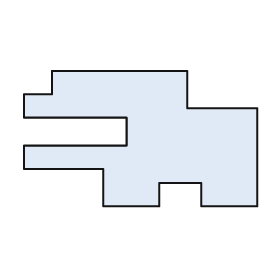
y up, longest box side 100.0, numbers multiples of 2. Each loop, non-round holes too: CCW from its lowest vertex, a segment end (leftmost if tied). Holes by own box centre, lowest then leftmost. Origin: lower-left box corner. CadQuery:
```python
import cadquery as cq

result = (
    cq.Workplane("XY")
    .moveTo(34.0, 0.0)
    .lineTo(58.0, 0.0)
    .lineTo(58.0, 10.0)
    .lineTo(76.0, 10.0)
    .lineTo(76.0, 0.0)
    .lineTo(100.0, 0.0)
    .lineTo(100.0, 42.0)
    .lineTo(70.0, 42.0)
    .lineTo(70.0, 58.0)
    .lineTo(12.0, 58.0)
    .lineTo(12.0, 48.0)
    .lineTo(0.0, 48.0)
    .lineTo(0.0, 38.0)
    .lineTo(44.0, 38.0)
    .lineTo(44.0, 26.0)
    .lineTo(0.0, 26.0)
    .lineTo(0.0, 16.0)
    .lineTo(34.0, 16.0)
    .close()
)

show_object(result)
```